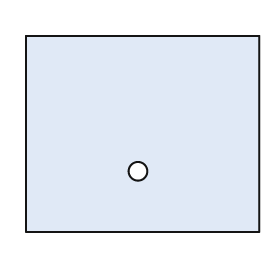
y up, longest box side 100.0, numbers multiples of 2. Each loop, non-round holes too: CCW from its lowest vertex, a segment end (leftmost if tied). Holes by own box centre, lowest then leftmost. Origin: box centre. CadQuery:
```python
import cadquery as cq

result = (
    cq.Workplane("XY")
    .moveTo(-50.0, -42.0)
    .lineTo(50.0, -42.0)
    .lineTo(50.0, 42.0)
    .lineTo(-50.0, 42.0)
    .close()
    .moveTo(-2.0, -16.0)
    .circle(4.0)
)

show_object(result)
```